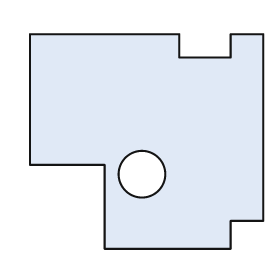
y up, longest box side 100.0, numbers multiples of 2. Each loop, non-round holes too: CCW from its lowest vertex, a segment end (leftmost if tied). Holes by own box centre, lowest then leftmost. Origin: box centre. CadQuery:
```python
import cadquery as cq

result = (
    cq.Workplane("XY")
    .moveTo(-18.0, -46.0)
    .lineTo(36.0, -46.0)
    .lineTo(36.0, -34.0)
    .lineTo(50.0, -34.0)
    .lineTo(50.0, 46.0)
    .lineTo(36.0, 46.0)
    .lineTo(36.0, 36.0)
    .lineTo(14.0, 36.0)
    .lineTo(14.0, 46.0)
    .lineTo(-50.0, 46.0)
    .lineTo(-50.0, -10.0)
    .lineTo(-18.0, -10.0)
    .close()
    .moveTo(-2.0, -14.0)
    .circle(10.0)
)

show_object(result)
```